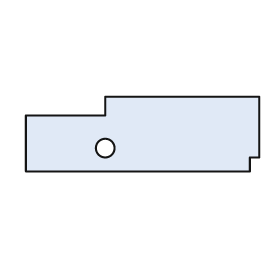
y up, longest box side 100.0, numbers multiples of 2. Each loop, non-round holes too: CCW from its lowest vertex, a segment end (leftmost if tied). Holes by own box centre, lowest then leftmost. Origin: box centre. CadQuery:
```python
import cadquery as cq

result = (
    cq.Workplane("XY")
    .moveTo(-50.0, -16.0)
    .lineTo(46.0, -16.0)
    .lineTo(46.0, -10.0)
    .lineTo(50.0, -10.0)
    .lineTo(50.0, 16.0)
    .lineTo(-16.0, 16.0)
    .lineTo(-16.0, 8.0)
    .lineTo(-50.0, 8.0)
    .close()
    .moveTo(-16.0, -6.0)
    .circle(4.0)
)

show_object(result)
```